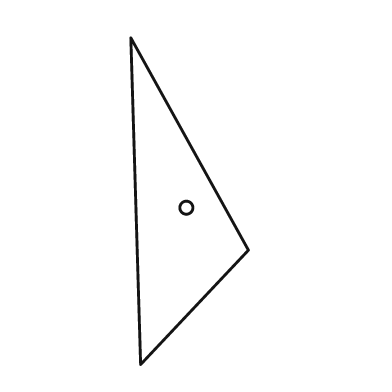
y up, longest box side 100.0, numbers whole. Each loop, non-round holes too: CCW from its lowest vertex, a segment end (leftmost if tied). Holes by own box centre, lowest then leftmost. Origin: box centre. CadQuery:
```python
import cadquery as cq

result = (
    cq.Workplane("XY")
    .moveTo(-15.0, -50.0)
    .lineTo(18.0, -15.0)
    .lineTo(-18.0, 50.0)
    .close()
    .moveTo(-1.0, -2.0)
    .circle(2.0)
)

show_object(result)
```